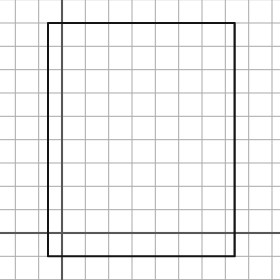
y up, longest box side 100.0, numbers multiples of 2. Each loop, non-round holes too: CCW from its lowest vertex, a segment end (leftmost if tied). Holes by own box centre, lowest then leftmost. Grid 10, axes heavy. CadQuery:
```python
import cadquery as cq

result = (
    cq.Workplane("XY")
    .moveTo(-6.0, -10.0)
    .lineTo(74.0, -10.0)
    .lineTo(74.0, 90.0)
    .lineTo(-6.0, 90.0)
    .close()
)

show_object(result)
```